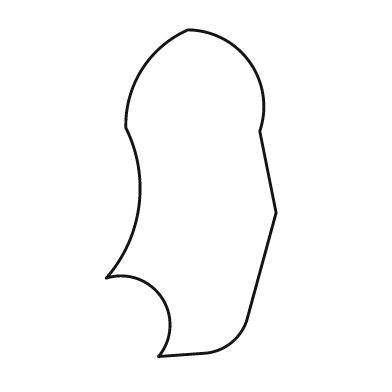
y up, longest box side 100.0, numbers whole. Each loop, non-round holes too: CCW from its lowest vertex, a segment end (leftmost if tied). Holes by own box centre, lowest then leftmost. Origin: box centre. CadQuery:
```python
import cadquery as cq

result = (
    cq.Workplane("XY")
    .moveTo(-10.0, -50.0)
    .lineTo(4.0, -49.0)
    .threePointArc((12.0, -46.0), (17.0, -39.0))
    .lineTo(26.0, -6.0)
    .lineTo(21.0, 19.0)
    .threePointArc((18.0, 40.0), (-1.0, 50.0))
    .threePointArc((-15.0, 38.0), (-20.0, 20.0))
    .threePointArc((-16.0, -4.0), (-26.0, -26.0))
    .threePointArc((-9.0, -32.0), (-10.0, -50.0))
    .close()
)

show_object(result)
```